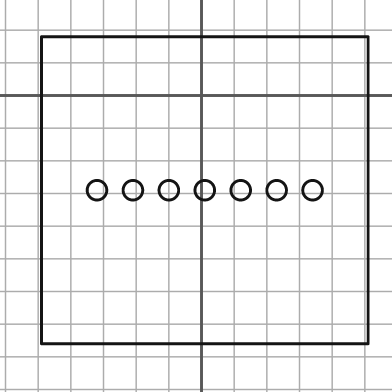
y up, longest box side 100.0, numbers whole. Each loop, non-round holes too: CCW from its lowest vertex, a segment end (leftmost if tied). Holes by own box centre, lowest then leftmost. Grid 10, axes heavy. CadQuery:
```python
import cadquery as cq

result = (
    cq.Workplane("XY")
    .moveTo(-49.0, -76.0)
    .lineTo(51.0, -76.0)
    .lineTo(51.0, 18.0)
    .lineTo(-49.0, 18.0)
    .close()
    .moveTo(-32.0, -29.0)
    .circle(3.0)
    .moveTo(-21.0, -29.0)
    .circle(3.0)
    .moveTo(-10.0, -29.0)
    .circle(3.0)
    .moveTo(1.0, -29.0)
    .circle(3.0)
    .moveTo(12.0, -29.0)
    .circle(3.0)
    .moveTo(23.0, -29.0)
    .circle(3.0)
    .moveTo(34.0, -29.0)
    .circle(3.0)
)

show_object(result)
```